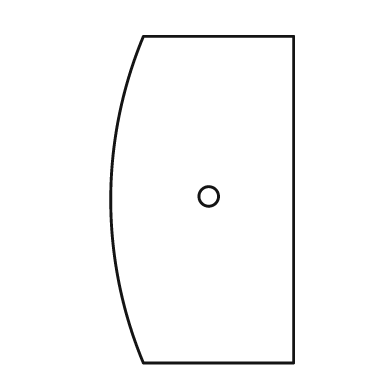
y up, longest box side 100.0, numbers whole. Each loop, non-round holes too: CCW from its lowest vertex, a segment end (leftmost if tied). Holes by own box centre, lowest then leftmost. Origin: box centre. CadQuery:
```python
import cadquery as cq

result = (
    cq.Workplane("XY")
    .moveTo(-18.0, -50.0)
    .lineTo(28.0, -50.0)
    .lineTo(28.0, 50.0)
    .lineTo(-18.0, 50.0)
    .threePointArc((-28.0, 0.0), (-18.0, -50.0))
    .close()
    .moveTo(2.0, 1.0)
    .circle(3.0)
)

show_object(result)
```